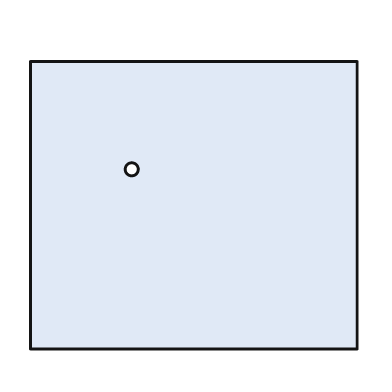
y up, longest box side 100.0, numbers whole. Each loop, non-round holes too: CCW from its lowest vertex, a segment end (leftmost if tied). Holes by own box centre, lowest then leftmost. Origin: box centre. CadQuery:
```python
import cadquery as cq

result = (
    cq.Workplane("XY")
    .moveTo(-50.0, -44.0)
    .lineTo(50.0, -44.0)
    .lineTo(50.0, 44.0)
    .lineTo(-50.0, 44.0)
    .close()
    .moveTo(-19.0, 11.0)
    .circle(2.0)
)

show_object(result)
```